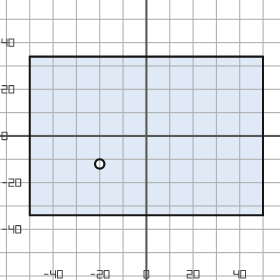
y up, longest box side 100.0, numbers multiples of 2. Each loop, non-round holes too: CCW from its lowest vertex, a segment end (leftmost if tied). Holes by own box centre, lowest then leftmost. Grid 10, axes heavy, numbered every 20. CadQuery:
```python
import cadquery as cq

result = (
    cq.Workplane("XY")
    .moveTo(-50.0, -34.0)
    .lineTo(50.0, -34.0)
    .lineTo(50.0, 34.0)
    .lineTo(-50.0, 34.0)
    .close()
    .moveTo(-20.0, -12.0)
    .circle(2.0)
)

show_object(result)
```